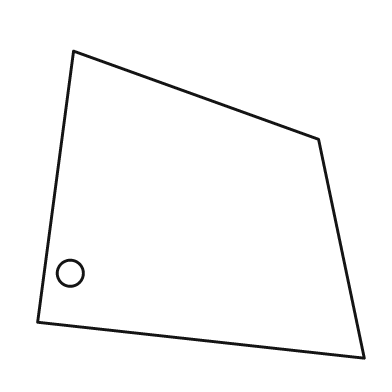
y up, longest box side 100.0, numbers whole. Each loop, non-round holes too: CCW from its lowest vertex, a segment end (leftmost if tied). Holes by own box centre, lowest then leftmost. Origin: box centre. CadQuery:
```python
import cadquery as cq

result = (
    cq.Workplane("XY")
    .moveTo(50.0, -47.0)
    .lineTo(36.0, 20.0)
    .lineTo(-39.0, 47.0)
    .lineTo(-50.0, -36.0)
    .close()
    .moveTo(-40.0, -21.0)
    .circle(4.0)
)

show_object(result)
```